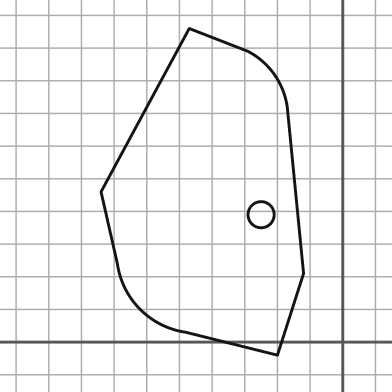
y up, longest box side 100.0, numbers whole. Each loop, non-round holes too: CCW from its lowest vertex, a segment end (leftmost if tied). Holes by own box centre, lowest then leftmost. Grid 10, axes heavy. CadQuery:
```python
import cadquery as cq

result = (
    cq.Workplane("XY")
    .moveTo(-20.0, -4.0)
    .lineTo(-12.0, 21.0)
    .lineTo(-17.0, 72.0)
    .threePointArc((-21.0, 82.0), (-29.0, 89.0))
    .lineTo(-47.0, 96.0)
    .lineTo(-74.0, 46.0)
    .lineTo(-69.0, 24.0)
    .threePointArc((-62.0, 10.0), (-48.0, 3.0))
    .close()
    .moveTo(-25.0, 39.0)
    .circle(4.0)
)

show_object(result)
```